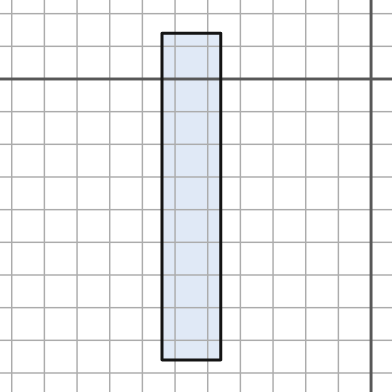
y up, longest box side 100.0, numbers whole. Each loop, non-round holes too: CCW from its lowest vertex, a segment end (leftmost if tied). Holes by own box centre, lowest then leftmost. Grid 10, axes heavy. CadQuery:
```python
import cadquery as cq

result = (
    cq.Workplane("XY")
    .moveTo(-64.0, -86.0)
    .lineTo(-46.0, -86.0)
    .lineTo(-46.0, 14.0)
    .lineTo(-64.0, 14.0)
    .close()
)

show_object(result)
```